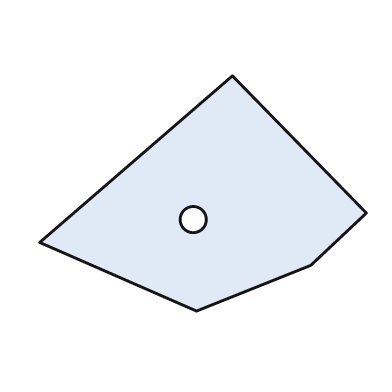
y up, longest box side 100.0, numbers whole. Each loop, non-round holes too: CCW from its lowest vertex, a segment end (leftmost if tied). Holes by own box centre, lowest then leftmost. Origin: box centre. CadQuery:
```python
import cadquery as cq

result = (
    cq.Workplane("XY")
    .moveTo(-2.0, -36.0)
    .lineTo(33.0, -22.0)
    .lineTo(50.0, -6.0)
    .lineTo(9.0, 36.0)
    .lineTo(-50.0, -15.0)
    .close()
    .moveTo(-3.0, -8.0)
    .circle(4.0)
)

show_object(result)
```